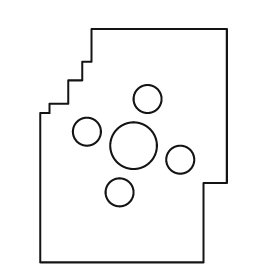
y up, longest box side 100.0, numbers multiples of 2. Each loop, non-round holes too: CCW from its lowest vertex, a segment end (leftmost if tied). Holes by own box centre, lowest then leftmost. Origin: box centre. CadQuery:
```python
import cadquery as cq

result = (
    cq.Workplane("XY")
    .moveTo(-40.0, -50.0)
    .lineTo(30.0, -50.0)
    .lineTo(30.0, -16.0)
    .lineTo(40.0, -16.0)
    .lineTo(40.0, 50.0)
    .lineTo(-18.0, 50.0)
    .lineTo(-18.0, 36.0)
    .lineTo(-22.0, 36.0)
    .lineTo(-22.0, 28.0)
    .lineTo(-28.0, 28.0)
    .lineTo(-28.0, 18.0)
    .lineTo(-36.0, 18.0)
    .lineTo(-36.0, 14.0)
    .lineTo(-40.0, 14.0)
    .close()
    .moveTo(-6.0, -20.0)
    .circle(6.0)
    .moveTo(20.0, -6.0)
    .circle(6.0)
    .moveTo(0.0, 0.0)
    .circle(10.0)
    .moveTo(-20.0, 6.0)
    .circle(6.0)
    .moveTo(6.0, 20.0)
    .circle(6.0)
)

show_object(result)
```